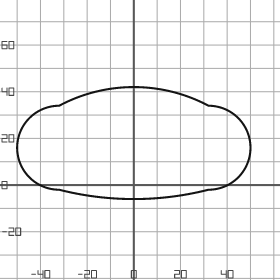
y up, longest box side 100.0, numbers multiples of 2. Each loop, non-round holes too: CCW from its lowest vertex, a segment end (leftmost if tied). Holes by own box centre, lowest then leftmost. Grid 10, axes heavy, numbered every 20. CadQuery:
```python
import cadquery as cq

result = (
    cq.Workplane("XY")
    .moveTo(-32.0, -2.0)
    .threePointArc((0.0, -6.0), (32.0, -2.0))
    .threePointArc((50.0, 16.0), (32.0, 34.0))
    .threePointArc((0.0, 42.0), (-32.0, 34.0))
    .threePointArc((-50.0, 16.0), (-32.0, -2.0))
    .close()
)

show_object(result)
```